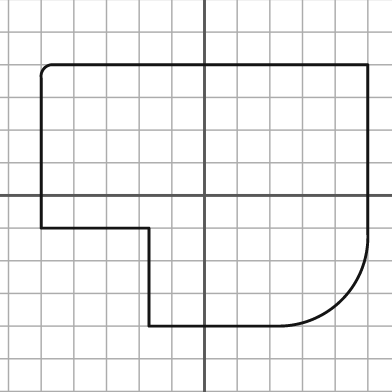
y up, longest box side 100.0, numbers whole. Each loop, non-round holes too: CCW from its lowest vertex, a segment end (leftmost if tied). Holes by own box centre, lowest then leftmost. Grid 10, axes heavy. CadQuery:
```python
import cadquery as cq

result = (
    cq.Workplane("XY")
    .moveTo(-17.0, -40.0)
    .lineTo(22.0, -40.0)
    .threePointArc((42.0, -32.0), (50.0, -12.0))
    .lineTo(50.0, 40.0)
    .lineTo(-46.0, 40.0)
    .threePointArc((-49.0, 39.0), (-50.0, 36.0))
    .lineTo(-50.0, -10.0)
    .lineTo(-17.0, -10.0)
    .close()
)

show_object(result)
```